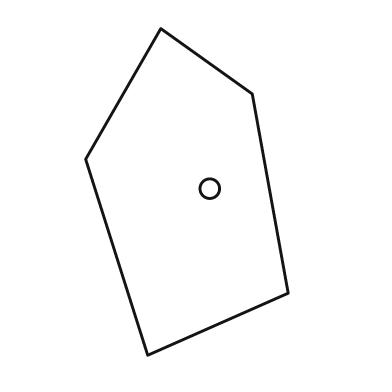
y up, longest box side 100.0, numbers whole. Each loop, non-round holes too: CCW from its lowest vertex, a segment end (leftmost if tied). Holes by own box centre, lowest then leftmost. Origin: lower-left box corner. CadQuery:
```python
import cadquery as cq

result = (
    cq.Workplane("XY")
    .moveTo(19.0, 0.0)
    .lineTo(62.0, 19.0)
    .lineTo(51.0, 80.0)
    .lineTo(23.0, 100.0)
    .lineTo(0.0, 60.0)
    .close()
    .moveTo(38.0, 51.0)
    .circle(3.0)
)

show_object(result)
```